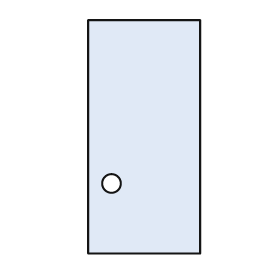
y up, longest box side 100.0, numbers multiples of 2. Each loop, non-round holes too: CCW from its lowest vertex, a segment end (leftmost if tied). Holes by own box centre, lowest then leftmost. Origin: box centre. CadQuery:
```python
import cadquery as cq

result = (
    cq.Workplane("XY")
    .moveTo(-24.0, -50.0)
    .lineTo(24.0, -50.0)
    .lineTo(24.0, 50.0)
    .lineTo(-24.0, 50.0)
    .close()
    .moveTo(-14.0, -20.0)
    .circle(4.0)
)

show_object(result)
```